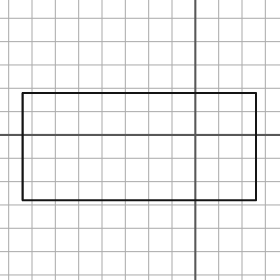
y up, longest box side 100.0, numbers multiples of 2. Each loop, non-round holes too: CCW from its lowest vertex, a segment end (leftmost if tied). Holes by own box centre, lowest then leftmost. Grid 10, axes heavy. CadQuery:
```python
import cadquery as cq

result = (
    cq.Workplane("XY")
    .moveTo(-74.0, -28.0)
    .lineTo(26.0, -28.0)
    .lineTo(26.0, 18.0)
    .lineTo(-74.0, 18.0)
    .close()
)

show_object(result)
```